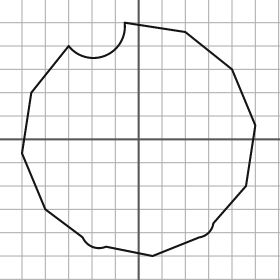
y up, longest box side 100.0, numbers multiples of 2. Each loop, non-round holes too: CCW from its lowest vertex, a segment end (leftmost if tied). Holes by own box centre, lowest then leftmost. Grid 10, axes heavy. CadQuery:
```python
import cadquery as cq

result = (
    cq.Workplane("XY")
    .moveTo(6.0, -50.0)
    .lineTo(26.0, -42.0)
    .threePointArc((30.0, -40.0), (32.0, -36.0))
    .lineTo(46.0, -20.0)
    .lineTo(50.0, 6.0)
    .lineTo(40.0, 30.0)
    .lineTo(20.0, 46.0)
    .lineTo(-6.0, 50.0)
    .threePointArc((-14.0, 36.0), (-30.0, 40.0))
    .lineTo(-46.0, 20.0)
    .lineTo(-50.0, -6.0)
    .lineTo(-40.0, -30.0)
    .lineTo(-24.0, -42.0)
    .threePointArc((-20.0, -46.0), (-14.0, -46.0))
    .close()
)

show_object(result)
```